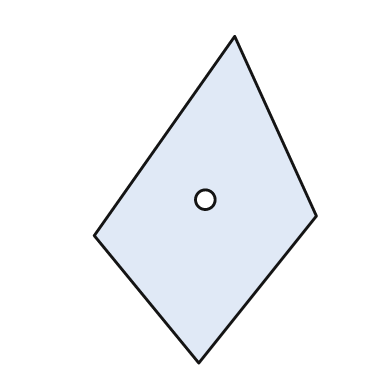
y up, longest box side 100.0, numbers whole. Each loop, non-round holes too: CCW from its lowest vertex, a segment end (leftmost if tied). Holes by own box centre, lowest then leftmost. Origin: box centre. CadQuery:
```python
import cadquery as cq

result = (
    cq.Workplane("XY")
    .moveTo(-2.0, -50.0)
    .lineTo(34.0, -5.0)
    .lineTo(9.0, 50.0)
    .lineTo(-34.0, -11.0)
    .close()
    .moveTo(0.0, 0.0)
    .circle(3.0)
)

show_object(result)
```